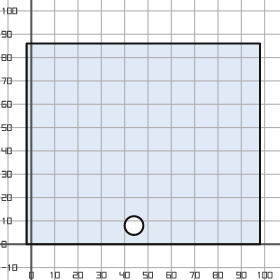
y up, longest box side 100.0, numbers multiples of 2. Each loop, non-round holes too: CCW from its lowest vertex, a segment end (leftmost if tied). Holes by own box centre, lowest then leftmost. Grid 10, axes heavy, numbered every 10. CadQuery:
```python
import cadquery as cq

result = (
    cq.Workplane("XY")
    .moveTo(-2.0, 0.0)
    .lineTo(98.0, 0.0)
    .lineTo(98.0, 86.0)
    .lineTo(-2.0, 86.0)
    .close()
    .moveTo(44.0, 8.0)
    .circle(4.0)
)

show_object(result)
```